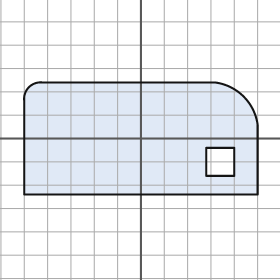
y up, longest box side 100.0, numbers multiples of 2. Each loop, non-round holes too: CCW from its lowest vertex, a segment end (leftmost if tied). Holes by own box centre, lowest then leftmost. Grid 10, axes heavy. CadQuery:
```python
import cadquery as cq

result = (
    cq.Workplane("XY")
    .moveTo(-50.0, -24.0)
    .lineTo(50.0, -24.0)
    .lineTo(50.0, 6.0)
    .threePointArc((44.0, 18.0), (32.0, 24.0))
    .lineTo(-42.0, 24.0)
    .threePointArc((-48.0, 22.0), (-50.0, 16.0))
    .close()
    .moveTo(28.0, -16.0)
    .lineTo(40.0, -16.0)
    .lineTo(40.0, -4.0)
    .lineTo(28.0, -4.0)
    .close()
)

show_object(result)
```